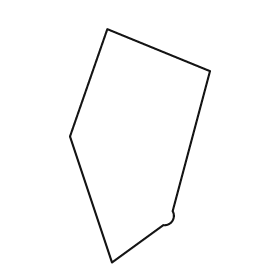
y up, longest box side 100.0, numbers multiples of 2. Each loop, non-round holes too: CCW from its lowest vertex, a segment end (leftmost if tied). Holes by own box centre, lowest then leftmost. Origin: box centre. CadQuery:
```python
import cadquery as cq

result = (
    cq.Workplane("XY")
    .moveTo(-12.0, -50.0)
    .lineTo(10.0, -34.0)
    .threePointArc((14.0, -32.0), (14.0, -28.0))
    .lineTo(30.0, 32.0)
    .lineTo(-14.0, 50.0)
    .lineTo(-30.0, 4.0)
    .close()
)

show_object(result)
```